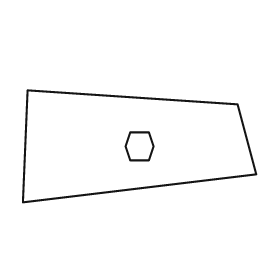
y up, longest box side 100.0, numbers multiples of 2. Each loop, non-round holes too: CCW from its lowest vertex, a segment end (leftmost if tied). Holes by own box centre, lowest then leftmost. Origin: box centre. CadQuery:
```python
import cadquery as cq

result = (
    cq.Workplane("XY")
    .moveTo(-50.0, -24.0)
    .lineTo(50.0, -12.0)
    .lineTo(42.0, 18.0)
    .lineTo(-48.0, 24.0)
    .close()
    .moveTo(-4.0, -6.0)
    .lineTo(4.0, -6.0)
    .lineTo(6.0, 0.0)
    .lineTo(4.0, 6.0)
    .lineTo(-4.0, 6.0)
    .lineTo(-6.0, 0.0)
    .close()
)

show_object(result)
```